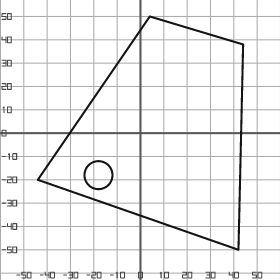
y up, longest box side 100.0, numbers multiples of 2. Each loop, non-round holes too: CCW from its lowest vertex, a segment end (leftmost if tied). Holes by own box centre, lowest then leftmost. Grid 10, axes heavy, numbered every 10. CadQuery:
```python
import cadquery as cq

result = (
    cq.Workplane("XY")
    .moveTo(42.0, -50.0)
    .lineTo(44.0, 38.0)
    .lineTo(4.0, 50.0)
    .lineTo(-44.0, -20.0)
    .close()
    .moveTo(-18.0, -18.0)
    .circle(6.0)
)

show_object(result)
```